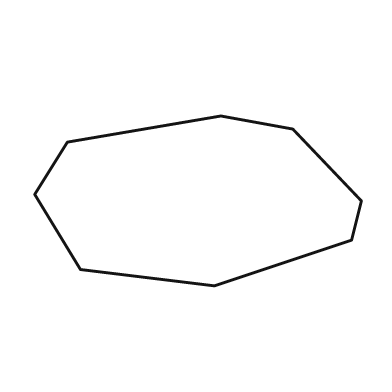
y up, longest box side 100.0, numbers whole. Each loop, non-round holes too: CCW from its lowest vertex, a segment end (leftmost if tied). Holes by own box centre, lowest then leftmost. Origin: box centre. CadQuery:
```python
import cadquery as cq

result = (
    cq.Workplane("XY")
    .moveTo(5.0, -26.0)
    .lineTo(47.0, -12.0)
    .lineTo(50.0, 0.0)
    .lineTo(29.0, 22.0)
    .lineTo(7.0, 26.0)
    .lineTo(-40.0, 18.0)
    .lineTo(-50.0, 2.0)
    .lineTo(-36.0, -21.0)
    .close()
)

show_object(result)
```